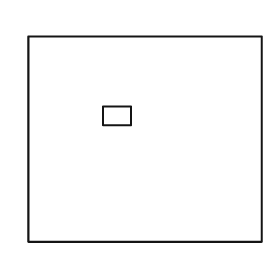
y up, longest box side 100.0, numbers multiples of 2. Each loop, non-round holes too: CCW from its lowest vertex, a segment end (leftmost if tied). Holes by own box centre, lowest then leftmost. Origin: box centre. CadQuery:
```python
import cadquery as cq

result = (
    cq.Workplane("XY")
    .moveTo(-50.0, -44.0)
    .lineTo(50.0, -44.0)
    .lineTo(50.0, 44.0)
    .lineTo(-50.0, 44.0)
    .close()
    .moveTo(-18.0, 6.0)
    .lineTo(-6.0, 6.0)
    .lineTo(-6.0, 14.0)
    .lineTo(-18.0, 14.0)
    .close()
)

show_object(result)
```